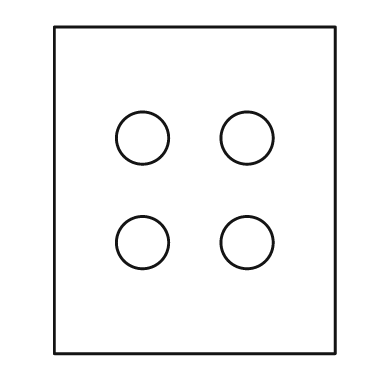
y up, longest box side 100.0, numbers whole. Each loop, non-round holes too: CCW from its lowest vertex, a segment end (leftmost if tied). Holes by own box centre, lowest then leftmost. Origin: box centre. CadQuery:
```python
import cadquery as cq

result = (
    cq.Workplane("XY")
    .moveTo(-43.0, -50.0)
    .lineTo(43.0, -50.0)
    .lineTo(43.0, 50.0)
    .lineTo(-43.0, 50.0)
    .close()
    .moveTo(-16.0, -16.0)
    .circle(8.0)
    .moveTo(16.0, -16.0)
    .circle(8.0)
    .moveTo(-16.0, 16.0)
    .circle(8.0)
    .moveTo(16.0, 16.0)
    .circle(8.0)
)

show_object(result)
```